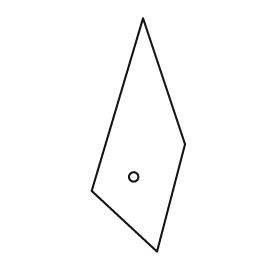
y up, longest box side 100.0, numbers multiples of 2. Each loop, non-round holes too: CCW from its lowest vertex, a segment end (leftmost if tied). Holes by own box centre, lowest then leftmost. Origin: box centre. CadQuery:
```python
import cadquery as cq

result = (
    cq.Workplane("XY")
    .moveTo(8.0, -50.0)
    .lineTo(20.0, -4.0)
    .lineTo(2.0, 50.0)
    .lineTo(-20.0, -24.0)
    .close()
    .moveTo(-2.0, -18.0)
    .circle(2.0)
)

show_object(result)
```